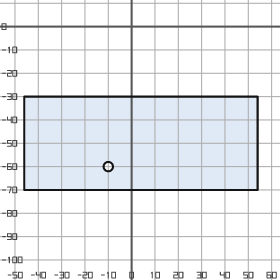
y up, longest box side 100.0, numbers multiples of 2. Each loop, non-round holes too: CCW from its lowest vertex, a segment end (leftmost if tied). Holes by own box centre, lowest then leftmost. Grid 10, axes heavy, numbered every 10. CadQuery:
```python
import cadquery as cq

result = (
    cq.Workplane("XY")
    .moveTo(-46.0, -70.0)
    .lineTo(54.0, -70.0)
    .lineTo(54.0, -30.0)
    .lineTo(-46.0, -30.0)
    .close()
    .moveTo(-10.0, -60.0)
    .circle(2.0)
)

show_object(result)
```